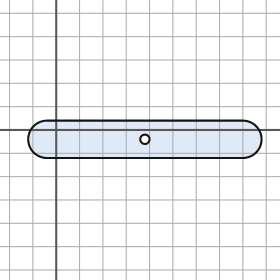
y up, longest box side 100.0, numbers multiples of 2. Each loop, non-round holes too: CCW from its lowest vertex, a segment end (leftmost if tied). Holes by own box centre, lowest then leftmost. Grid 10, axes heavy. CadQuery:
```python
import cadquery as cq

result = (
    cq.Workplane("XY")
    .moveTo(-4.0, -12.0)
    .lineTo(80.0, -12.0)
    .threePointArc((88.0, -4.0), (80.0, 4.0))
    .lineTo(-4.0, 4.0)
    .threePointArc((-12.0, -4.0), (-4.0, -12.0))
    .close()
    .moveTo(38.0, -4.0)
    .circle(2.0)
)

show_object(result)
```